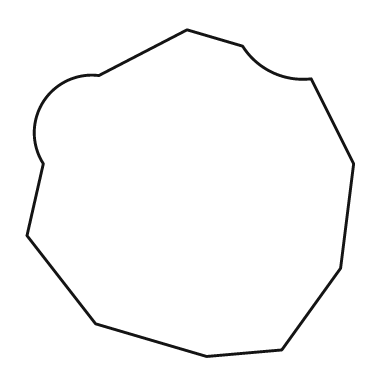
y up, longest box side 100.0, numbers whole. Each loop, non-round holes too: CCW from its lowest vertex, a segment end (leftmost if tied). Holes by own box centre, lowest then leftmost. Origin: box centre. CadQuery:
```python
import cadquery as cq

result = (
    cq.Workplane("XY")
    .moveTo(5.0, -50.0)
    .lineTo(28.0, -48.0)
    .lineTo(46.0, -23.0)
    .lineTo(50.0, 9.0)
    .lineTo(37.0, 35.0)
    .threePointArc((25.0, 37.0), (16.0, 45.0))
    .lineTo(-1.0, 50.0)
    .lineTo(-28.0, 36.0)
    .threePointArc((-45.0, 28.0), (-45.0, 9.0))
    .lineTo(-50.0, -13.0)
    .lineTo(-29.0, -40.0)
    .close()
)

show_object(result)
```